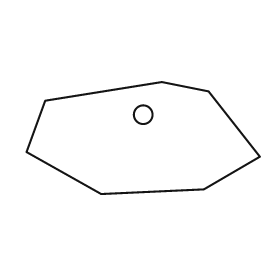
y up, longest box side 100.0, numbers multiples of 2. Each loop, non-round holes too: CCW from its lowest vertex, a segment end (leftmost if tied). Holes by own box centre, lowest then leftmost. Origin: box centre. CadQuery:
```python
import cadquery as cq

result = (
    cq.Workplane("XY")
    .moveTo(-18.0, -24.0)
    .lineTo(26.0, -22.0)
    .lineTo(50.0, -8.0)
    .lineTo(28.0, 20.0)
    .lineTo(8.0, 24.0)
    .lineTo(-42.0, 16.0)
    .lineTo(-50.0, -6.0)
    .close()
    .moveTo(0.0, 10.0)
    .circle(4.0)
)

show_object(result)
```